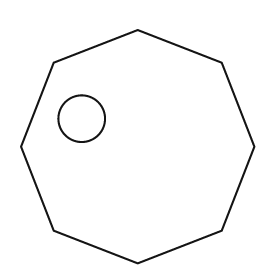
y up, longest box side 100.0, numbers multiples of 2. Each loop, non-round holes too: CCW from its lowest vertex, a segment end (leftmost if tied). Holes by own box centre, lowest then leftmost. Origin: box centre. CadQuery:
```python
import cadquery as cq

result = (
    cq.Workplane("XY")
    .moveTo(0.0, -50.0)
    .lineTo(36.0, -36.0)
    .lineTo(50.0, 0.0)
    .lineTo(36.0, 36.0)
    .lineTo(0.0, 50.0)
    .lineTo(-36.0, 36.0)
    .lineTo(-50.0, 0.0)
    .lineTo(-36.0, -36.0)
    .close()
    .moveTo(-24.0, 12.0)
    .circle(10.0)
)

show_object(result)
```